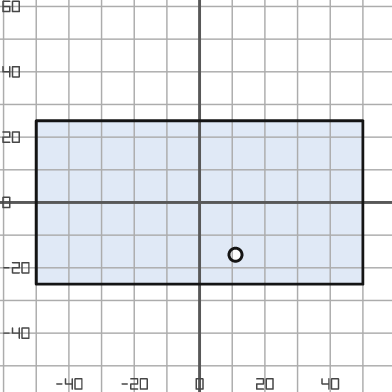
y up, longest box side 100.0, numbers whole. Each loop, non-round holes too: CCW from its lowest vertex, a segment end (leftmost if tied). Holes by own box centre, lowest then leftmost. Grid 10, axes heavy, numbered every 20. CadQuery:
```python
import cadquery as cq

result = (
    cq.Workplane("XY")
    .moveTo(-50.0, -25.0)
    .lineTo(50.0, -25.0)
    .lineTo(50.0, 25.0)
    .lineTo(-50.0, 25.0)
    .close()
    .moveTo(11.0, -16.0)
    .circle(2.0)
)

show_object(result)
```